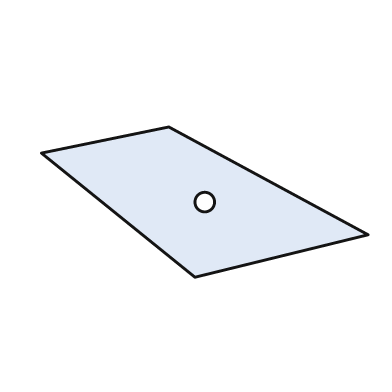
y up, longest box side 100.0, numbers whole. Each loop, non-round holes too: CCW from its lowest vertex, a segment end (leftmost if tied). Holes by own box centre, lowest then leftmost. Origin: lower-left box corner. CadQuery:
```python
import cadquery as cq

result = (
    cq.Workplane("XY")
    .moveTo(47.0, 0.0)
    .lineTo(100.0, 13.0)
    .lineTo(39.0, 46.0)
    .lineTo(0.0, 38.0)
    .close()
    .moveTo(50.0, 23.0)
    .circle(3.0)
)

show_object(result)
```